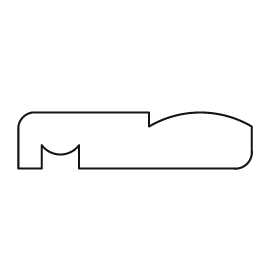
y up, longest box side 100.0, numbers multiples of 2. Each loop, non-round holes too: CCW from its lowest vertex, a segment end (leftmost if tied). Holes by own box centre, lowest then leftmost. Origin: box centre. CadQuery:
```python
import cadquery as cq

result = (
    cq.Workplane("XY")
    .moveTo(-50.0, -12.0)
    .lineTo(-40.0, -12.0)
    .lineTo(-40.0, -2.0)
    .threePointArc((-32.0, -6.0), (-24.0, -2.0))
    .lineTo(-24.0, -12.0)
    .lineTo(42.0, -12.0)
    .threePointArc((48.0, -10.0), (50.0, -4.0))
    .lineTo(50.0, 6.0)
    .threePointArc((28.0, 12.0), (6.0, 6.0))
    .lineTo(6.0, 12.0)
    .lineTo(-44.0, 12.0)
    .threePointArc((-48.0, 10.0), (-50.0, 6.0))
    .close()
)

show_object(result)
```